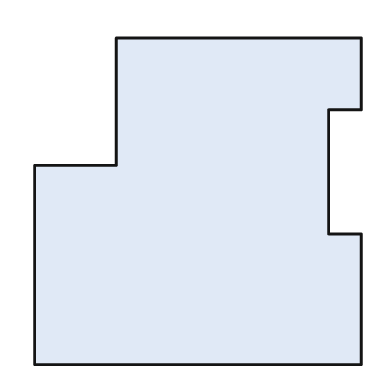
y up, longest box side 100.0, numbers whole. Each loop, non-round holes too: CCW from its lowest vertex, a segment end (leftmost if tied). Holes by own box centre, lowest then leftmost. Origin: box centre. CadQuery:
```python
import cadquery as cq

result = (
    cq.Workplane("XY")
    .moveTo(-50.0, -50.0)
    .lineTo(50.0, -50.0)
    .lineTo(50.0, -10.0)
    .lineTo(40.0, -10.0)
    .lineTo(40.0, 28.0)
    .lineTo(50.0, 28.0)
    .lineTo(50.0, 50.0)
    .lineTo(-25.0, 50.0)
    .lineTo(-25.0, 11.0)
    .lineTo(-50.0, 11.0)
    .close()
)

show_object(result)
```